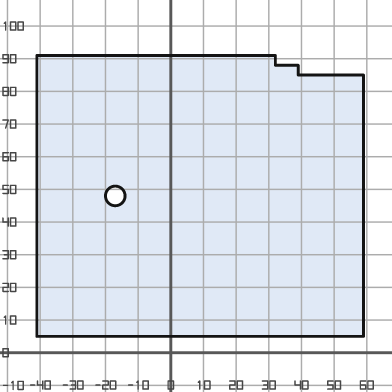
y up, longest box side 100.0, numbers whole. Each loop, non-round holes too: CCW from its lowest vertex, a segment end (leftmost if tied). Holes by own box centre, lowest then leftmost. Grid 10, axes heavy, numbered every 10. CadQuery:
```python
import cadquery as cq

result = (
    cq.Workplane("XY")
    .moveTo(-41.0, 5.0)
    .lineTo(59.0, 5.0)
    .lineTo(59.0, 85.0)
    .lineTo(39.0, 85.0)
    .lineTo(39.0, 88.0)
    .lineTo(32.0, 88.0)
    .lineTo(32.0, 91.0)
    .lineTo(-41.0, 91.0)
    .close()
    .moveTo(-17.0, 48.0)
    .circle(3.0)
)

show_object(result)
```